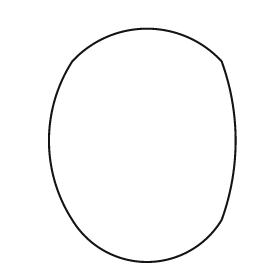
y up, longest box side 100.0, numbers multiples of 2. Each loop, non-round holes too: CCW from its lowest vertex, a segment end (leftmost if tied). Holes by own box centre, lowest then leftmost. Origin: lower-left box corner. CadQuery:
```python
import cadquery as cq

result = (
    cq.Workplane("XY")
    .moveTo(10.0, 18.0)
    .threePointArc((42.0, 0.0), (74.0, 18.0))
    .threePointArc((80.0, 52.0), (74.0, 86.0))
    .threePointArc((42.0, 100.0), (10.0, 86.0))
    .threePointArc((0.0, 52.0), (10.0, 18.0))
    .close()
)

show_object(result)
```